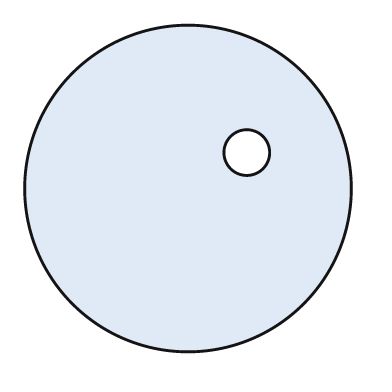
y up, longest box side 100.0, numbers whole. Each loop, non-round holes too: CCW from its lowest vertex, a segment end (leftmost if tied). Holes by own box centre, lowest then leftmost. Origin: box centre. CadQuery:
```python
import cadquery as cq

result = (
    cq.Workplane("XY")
    .moveTo(0.0, 0.0)
    .circle(50.0)
    .moveTo(18.0, 11.0)
    .circle(7.0)
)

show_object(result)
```